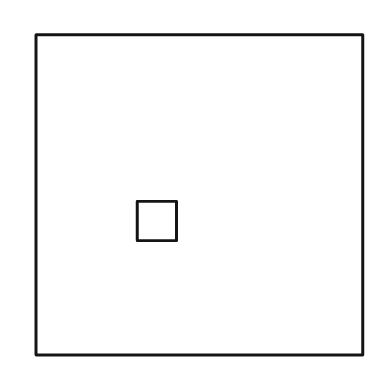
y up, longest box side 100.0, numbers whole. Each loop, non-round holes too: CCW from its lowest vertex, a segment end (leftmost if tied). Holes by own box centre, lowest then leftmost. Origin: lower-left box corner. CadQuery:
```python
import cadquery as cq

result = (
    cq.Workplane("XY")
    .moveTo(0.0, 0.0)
    .lineTo(100.0, 0.0)
    .lineTo(100.0, 98.0)
    .lineTo(0.0, 98.0)
    .close()
    .moveTo(31.0, 35.0)
    .lineTo(43.0, 35.0)
    .lineTo(43.0, 47.0)
    .lineTo(31.0, 47.0)
    .close()
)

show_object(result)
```